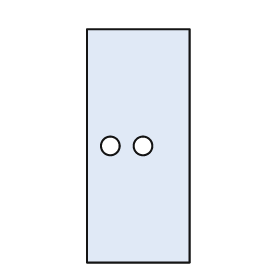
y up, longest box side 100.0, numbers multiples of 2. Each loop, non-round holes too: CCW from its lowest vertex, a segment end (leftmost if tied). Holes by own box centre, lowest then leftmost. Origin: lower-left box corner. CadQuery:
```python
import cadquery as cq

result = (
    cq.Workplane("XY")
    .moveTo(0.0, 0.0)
    .lineTo(44.0, 0.0)
    .lineTo(44.0, 100.0)
    .lineTo(0.0, 100.0)
    .close()
    .moveTo(10.0, 50.0)
    .circle(4.0)
    .moveTo(24.0, 50.0)
    .circle(4.0)
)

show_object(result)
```